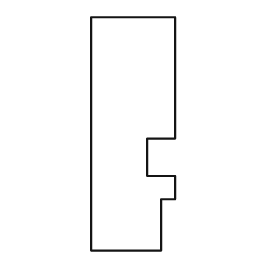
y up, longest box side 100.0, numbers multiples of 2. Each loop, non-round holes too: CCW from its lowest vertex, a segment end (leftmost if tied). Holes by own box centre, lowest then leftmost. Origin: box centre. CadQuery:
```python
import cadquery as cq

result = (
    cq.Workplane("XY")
    .moveTo(-18.0, -50.0)
    .lineTo(12.0, -50.0)
    .lineTo(12.0, -28.0)
    .lineTo(18.0, -28.0)
    .lineTo(18.0, -18.0)
    .lineTo(6.0, -18.0)
    .lineTo(6.0, -2.0)
    .lineTo(18.0, -2.0)
    .lineTo(18.0, 50.0)
    .lineTo(-18.0, 50.0)
    .close()
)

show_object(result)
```